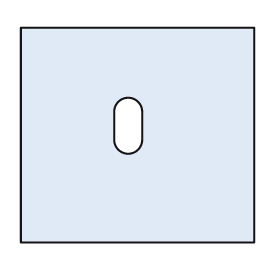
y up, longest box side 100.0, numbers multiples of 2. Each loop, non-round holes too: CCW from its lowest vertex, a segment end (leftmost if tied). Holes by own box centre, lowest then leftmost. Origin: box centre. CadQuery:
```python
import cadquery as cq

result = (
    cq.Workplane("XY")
    .moveTo(-50.0, -46.0)
    .lineTo(50.0, -46.0)
    .lineTo(50.0, 46.0)
    .lineTo(-50.0, 46.0)
    .close()
    .moveTo(-10.0, -2.0)
    .threePointArc((-4.0, -8.0), (2.0, -2.0))
    .lineTo(2.0, 10.0)
    .threePointArc((-4.0, 16.0), (-10.0, 10.0))
    .close()
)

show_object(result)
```